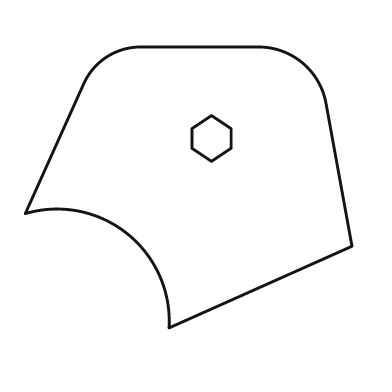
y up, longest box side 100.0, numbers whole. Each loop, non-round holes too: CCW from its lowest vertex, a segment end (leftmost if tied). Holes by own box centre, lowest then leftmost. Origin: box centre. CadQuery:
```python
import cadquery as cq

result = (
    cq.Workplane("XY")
    .moveTo(-6.0, -43.0)
    .lineTo(50.0, -18.0)
    .lineTo(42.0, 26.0)
    .threePointArc((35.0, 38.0), (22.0, 43.0))
    .lineTo(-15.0, 43.0)
    .threePointArc((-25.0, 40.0), (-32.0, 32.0))
    .lineTo(-50.0, -8.0)
    .threePointArc((-19.0, -14.0), (-6.0, -43.0))
    .close()
    .moveTo(7.0, 8.0)
    .lineTo(13.0, 12.0)
    .lineTo(13.0, 18.0)
    .lineTo(7.0, 22.0)
    .lineTo(1.0, 18.0)
    .lineTo(1.0, 12.0)
    .close()
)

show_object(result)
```